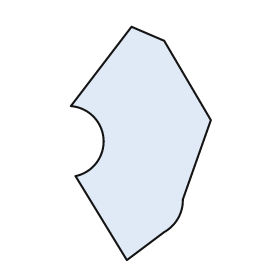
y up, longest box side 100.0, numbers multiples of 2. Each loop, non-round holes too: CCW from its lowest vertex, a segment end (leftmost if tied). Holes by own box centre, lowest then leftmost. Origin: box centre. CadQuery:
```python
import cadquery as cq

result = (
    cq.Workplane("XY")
    .moveTo(-6.0, -50.0)
    .lineTo(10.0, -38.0)
    .threePointArc((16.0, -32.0), (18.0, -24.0))
    .lineTo(30.0, 10.0)
    .lineTo(10.0, 44.0)
    .lineTo(-4.0, 50.0)
    .lineTo(-30.0, 16.0)
    .threePointArc((-16.0, 2.0), (-28.0, -14.0))
    .close()
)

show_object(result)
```